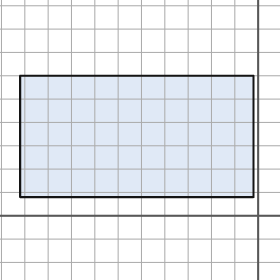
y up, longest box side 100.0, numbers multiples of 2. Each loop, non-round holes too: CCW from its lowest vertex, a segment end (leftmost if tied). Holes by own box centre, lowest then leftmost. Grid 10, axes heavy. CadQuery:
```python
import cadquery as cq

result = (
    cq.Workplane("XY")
    .moveTo(-102.0, 8.0)
    .lineTo(-2.0, 8.0)
    .lineTo(-2.0, 60.0)
    .lineTo(-102.0, 60.0)
    .close()
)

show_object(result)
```